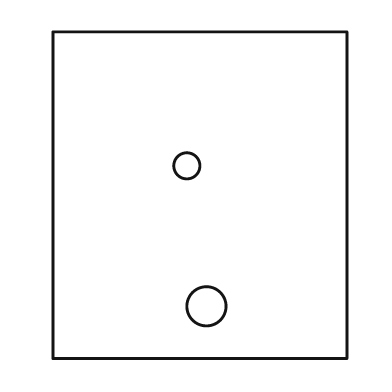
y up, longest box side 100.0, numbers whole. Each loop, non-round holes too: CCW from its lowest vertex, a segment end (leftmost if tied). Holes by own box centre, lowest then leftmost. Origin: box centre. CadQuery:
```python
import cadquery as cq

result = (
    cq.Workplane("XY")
    .moveTo(-45.0, -50.0)
    .lineTo(45.0, -50.0)
    .lineTo(45.0, 50.0)
    .lineTo(-45.0, 50.0)
    .close()
    .moveTo(2.0, -34.0)
    .circle(6.0)
    .moveTo(-4.0, 9.0)
    .circle(4.0)
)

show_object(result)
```